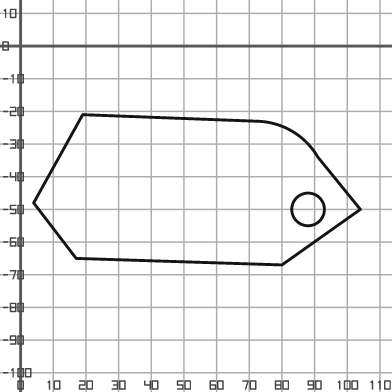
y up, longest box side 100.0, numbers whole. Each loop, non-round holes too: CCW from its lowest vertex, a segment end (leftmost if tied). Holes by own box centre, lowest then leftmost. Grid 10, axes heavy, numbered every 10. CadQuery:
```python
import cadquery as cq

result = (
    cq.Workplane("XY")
    .moveTo(80.0, -67.0)
    .lineTo(104.0, -50.0)
    .lineTo(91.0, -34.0)
    .threePointArc((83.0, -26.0), (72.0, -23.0))
    .lineTo(19.0, -21.0)
    .lineTo(4.0, -48.0)
    .lineTo(17.0, -65.0)
    .close()
    .moveTo(88.0, -50.0)
    .circle(5.0)
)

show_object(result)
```